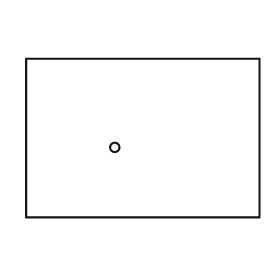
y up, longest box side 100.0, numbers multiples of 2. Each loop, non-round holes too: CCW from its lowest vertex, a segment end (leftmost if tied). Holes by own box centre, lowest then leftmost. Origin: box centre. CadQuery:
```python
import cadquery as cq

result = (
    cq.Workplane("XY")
    .moveTo(-50.0, -34.0)
    .lineTo(50.0, -34.0)
    .lineTo(50.0, 34.0)
    .lineTo(-50.0, 34.0)
    .close()
    .moveTo(-12.0, -4.0)
    .circle(2.0)
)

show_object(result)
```